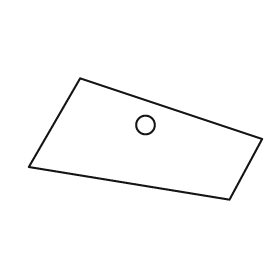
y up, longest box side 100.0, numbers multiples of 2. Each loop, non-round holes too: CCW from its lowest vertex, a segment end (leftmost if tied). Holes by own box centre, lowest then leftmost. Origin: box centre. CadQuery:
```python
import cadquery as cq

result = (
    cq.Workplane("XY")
    .moveTo(36.0, -26.0)
    .lineTo(50.0, 0.0)
    .lineTo(-28.0, 26.0)
    .lineTo(-50.0, -12.0)
    .close()
    .moveTo(0.0, 6.0)
    .circle(4.0)
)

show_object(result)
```